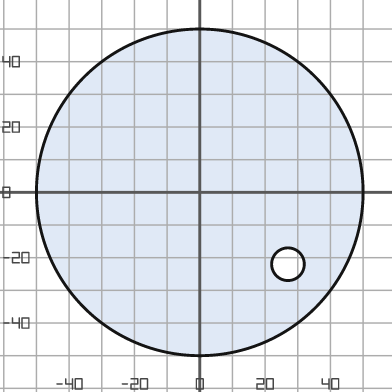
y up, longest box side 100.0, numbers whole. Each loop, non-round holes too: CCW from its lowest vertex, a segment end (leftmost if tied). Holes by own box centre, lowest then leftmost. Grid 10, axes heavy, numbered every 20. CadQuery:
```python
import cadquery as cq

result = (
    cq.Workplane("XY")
    .moveTo(0.0, 0.0)
    .circle(50.0)
    .moveTo(27.0, -22.0)
    .circle(5.0)
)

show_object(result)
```